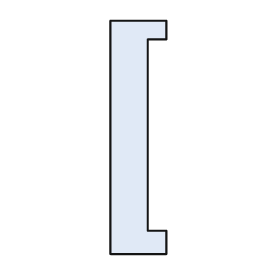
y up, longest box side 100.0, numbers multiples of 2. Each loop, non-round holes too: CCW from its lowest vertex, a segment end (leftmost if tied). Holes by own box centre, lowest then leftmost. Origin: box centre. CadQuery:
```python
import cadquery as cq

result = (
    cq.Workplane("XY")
    .moveTo(-12.0, -50.0)
    .lineTo(12.0, -50.0)
    .lineTo(12.0, -40.0)
    .lineTo(4.0, -40.0)
    .lineTo(4.0, 42.0)
    .lineTo(12.0, 42.0)
    .lineTo(12.0, 50.0)
    .lineTo(-12.0, 50.0)
    .close()
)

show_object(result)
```